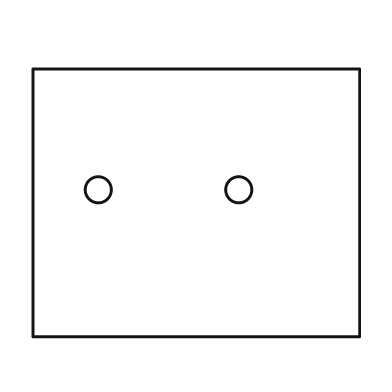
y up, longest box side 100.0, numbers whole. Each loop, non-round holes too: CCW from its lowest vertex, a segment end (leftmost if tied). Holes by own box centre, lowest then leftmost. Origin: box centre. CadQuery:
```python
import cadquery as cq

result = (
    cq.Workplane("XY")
    .moveTo(-50.0, -41.0)
    .lineTo(50.0, -41.0)
    .lineTo(50.0, 41.0)
    .lineTo(-50.0, 41.0)
    .close()
    .moveTo(-30.0, 4.0)
    .circle(4.0)
    .moveTo(13.0, 4.0)
    .circle(4.0)
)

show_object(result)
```